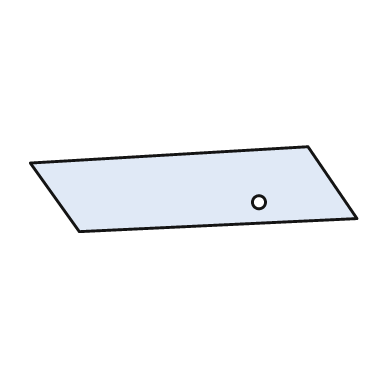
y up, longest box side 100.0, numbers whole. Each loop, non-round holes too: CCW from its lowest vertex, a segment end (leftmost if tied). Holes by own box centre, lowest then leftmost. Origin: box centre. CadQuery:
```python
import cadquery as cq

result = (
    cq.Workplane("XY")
    .moveTo(-35.0, -13.0)
    .lineTo(50.0, -9.0)
    .lineTo(35.0, 13.0)
    .lineTo(-50.0, 8.0)
    .close()
    .moveTo(20.0, -4.0)
    .circle(2.0)
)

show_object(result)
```